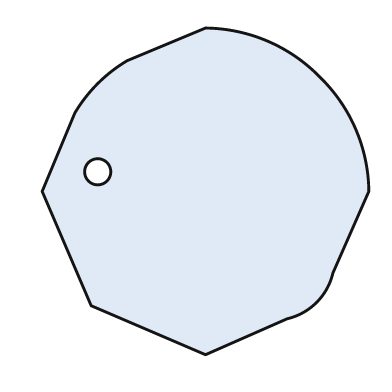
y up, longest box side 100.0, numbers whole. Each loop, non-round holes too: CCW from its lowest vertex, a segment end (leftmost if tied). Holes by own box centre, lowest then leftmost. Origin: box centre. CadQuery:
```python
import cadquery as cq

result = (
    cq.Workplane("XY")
    .moveTo(0.0, -50.0)
    .lineTo(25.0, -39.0)
    .threePointArc((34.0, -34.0), (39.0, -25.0))
    .lineTo(50.0, 0.0)
    .threePointArc((46.0, 19.0), (35.0, 35.0))
    .threePointArc((19.0, 46.0), (0.0, 50.0))
    .lineTo(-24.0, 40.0)
    .threePointArc((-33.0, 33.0), (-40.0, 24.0))
    .lineTo(-50.0, 0.0)
    .lineTo(-35.0, -35.0)
    .close()
    .moveTo(-33.0, 6.0)
    .circle(4.0)
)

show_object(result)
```